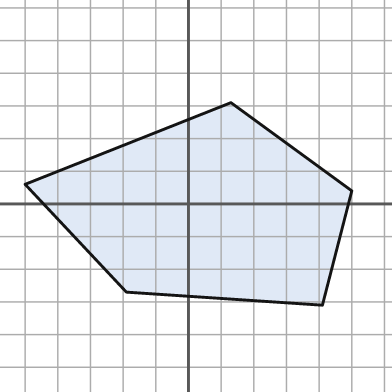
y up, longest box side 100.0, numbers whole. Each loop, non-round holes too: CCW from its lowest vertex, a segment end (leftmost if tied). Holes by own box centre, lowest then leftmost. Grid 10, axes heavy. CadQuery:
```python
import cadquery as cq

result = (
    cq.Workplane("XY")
    .moveTo(41.0, -31.0)
    .lineTo(50.0, 4.0)
    .lineTo(13.0, 31.0)
    .lineTo(-50.0, 6.0)
    .lineTo(-19.0, -27.0)
    .close()
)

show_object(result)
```